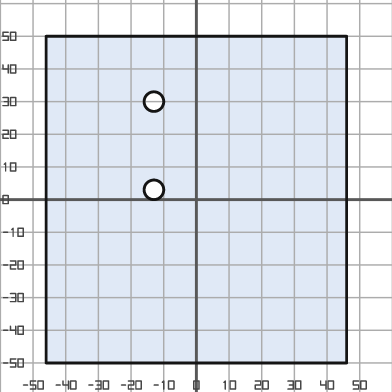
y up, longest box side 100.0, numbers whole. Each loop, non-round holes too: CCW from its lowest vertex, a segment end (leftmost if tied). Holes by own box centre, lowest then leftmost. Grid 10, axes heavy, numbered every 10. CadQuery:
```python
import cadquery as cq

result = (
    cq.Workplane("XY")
    .moveTo(-46.0, -50.0)
    .lineTo(46.0, -50.0)
    .lineTo(46.0, 50.0)
    .lineTo(-46.0, 50.0)
    .close()
    .moveTo(-13.0, 3.0)
    .circle(3.0)
    .moveTo(-13.0, 30.0)
    .circle(3.0)
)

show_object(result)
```